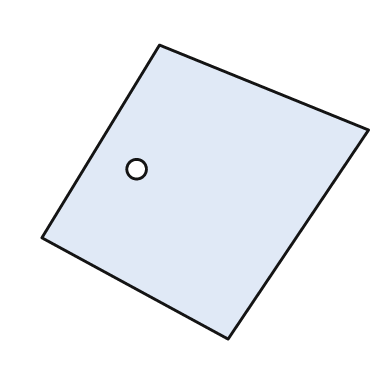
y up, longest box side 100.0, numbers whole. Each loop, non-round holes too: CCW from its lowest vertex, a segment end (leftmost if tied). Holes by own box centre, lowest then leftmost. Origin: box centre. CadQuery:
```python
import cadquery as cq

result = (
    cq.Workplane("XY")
    .moveTo(7.0, -45.0)
    .lineTo(50.0, 19.0)
    .lineTo(-14.0, 45.0)
    .lineTo(-50.0, -14.0)
    .close()
    .moveTo(-21.0, 7.0)
    .circle(3.0)
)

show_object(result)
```